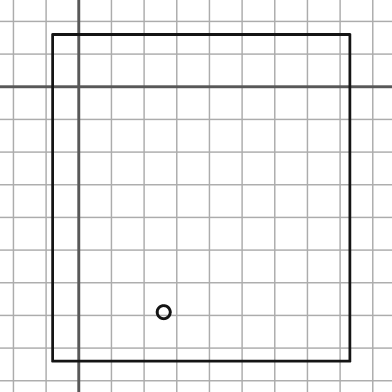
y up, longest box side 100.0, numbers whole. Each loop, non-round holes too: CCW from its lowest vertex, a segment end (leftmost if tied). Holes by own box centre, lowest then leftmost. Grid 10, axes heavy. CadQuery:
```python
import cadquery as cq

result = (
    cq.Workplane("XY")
    .moveTo(-8.0, -84.0)
    .lineTo(83.0, -84.0)
    .lineTo(83.0, 16.0)
    .lineTo(-8.0, 16.0)
    .close()
    .moveTo(26.0, -69.0)
    .circle(2.0)
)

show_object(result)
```